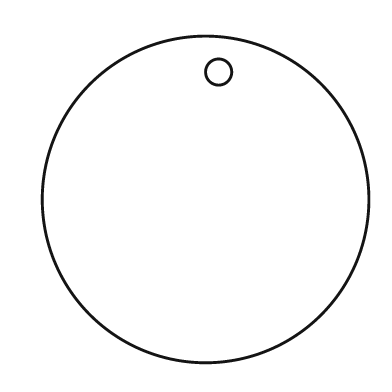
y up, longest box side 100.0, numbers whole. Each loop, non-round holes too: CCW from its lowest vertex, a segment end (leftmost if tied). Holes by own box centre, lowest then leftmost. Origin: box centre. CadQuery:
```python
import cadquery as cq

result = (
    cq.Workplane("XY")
    .moveTo(0.0, 0.0)
    .circle(50.0)
    .moveTo(4.0, 39.0)
    .circle(4.0)
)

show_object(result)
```